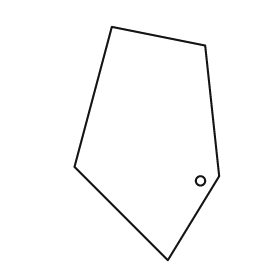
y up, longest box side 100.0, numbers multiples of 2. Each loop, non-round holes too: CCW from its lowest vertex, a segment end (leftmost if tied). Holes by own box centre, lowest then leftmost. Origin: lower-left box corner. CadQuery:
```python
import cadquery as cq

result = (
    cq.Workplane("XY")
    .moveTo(40.0, 0.0)
    .lineTo(62.0, 36.0)
    .lineTo(56.0, 92.0)
    .lineTo(16.0, 100.0)
    .lineTo(0.0, 40.0)
    .close()
    .moveTo(54.0, 34.0)
    .circle(2.0)
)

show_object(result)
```